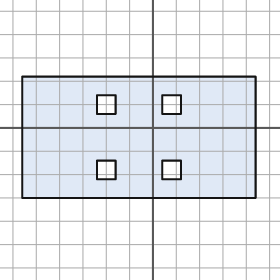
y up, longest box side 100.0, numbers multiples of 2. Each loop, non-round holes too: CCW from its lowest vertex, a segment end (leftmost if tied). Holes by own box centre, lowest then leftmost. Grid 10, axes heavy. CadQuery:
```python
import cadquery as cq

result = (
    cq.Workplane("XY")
    .moveTo(-56.0, -30.0)
    .lineTo(44.0, -30.0)
    .lineTo(44.0, 22.0)
    .lineTo(-56.0, 22.0)
    .close()
    .moveTo(-24.0, -22.0)
    .lineTo(-16.0, -22.0)
    .lineTo(-16.0, -14.0)
    .lineTo(-24.0, -14.0)
    .close()
    .moveTo(4.0, -22.0)
    .lineTo(12.0, -22.0)
    .lineTo(12.0, -14.0)
    .lineTo(4.0, -14.0)
    .close()
    .moveTo(-24.0, 6.0)
    .lineTo(-16.0, 6.0)
    .lineTo(-16.0, 14.0)
    .lineTo(-24.0, 14.0)
    .close()
    .moveTo(4.0, 6.0)
    .lineTo(12.0, 6.0)
    .lineTo(12.0, 14.0)
    .lineTo(4.0, 14.0)
    .close()
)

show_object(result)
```